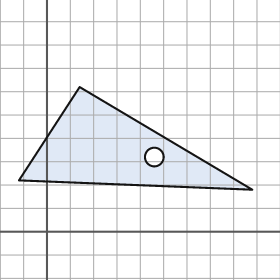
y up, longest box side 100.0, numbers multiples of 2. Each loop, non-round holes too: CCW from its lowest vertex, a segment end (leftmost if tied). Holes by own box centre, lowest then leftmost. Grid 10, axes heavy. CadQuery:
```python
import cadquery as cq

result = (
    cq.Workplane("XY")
    .moveTo(88.0, 18.0)
    .lineTo(14.0, 62.0)
    .lineTo(-12.0, 22.0)
    .close()
    .moveTo(46.0, 32.0)
    .circle(4.0)
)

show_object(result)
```